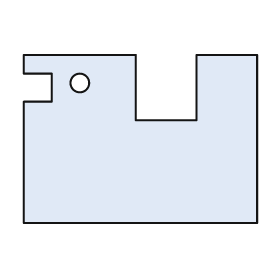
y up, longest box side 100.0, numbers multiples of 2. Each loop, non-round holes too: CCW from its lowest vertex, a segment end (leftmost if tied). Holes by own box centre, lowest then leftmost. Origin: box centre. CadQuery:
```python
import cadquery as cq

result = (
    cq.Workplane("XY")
    .moveTo(-50.0, -36.0)
    .lineTo(50.0, -36.0)
    .lineTo(50.0, 36.0)
    .lineTo(24.0, 36.0)
    .lineTo(24.0, 8.0)
    .lineTo(-2.0, 8.0)
    .lineTo(-2.0, 36.0)
    .lineTo(-50.0, 36.0)
    .lineTo(-50.0, 28.0)
    .lineTo(-38.0, 28.0)
    .lineTo(-38.0, 16.0)
    .lineTo(-50.0, 16.0)
    .close()
    .moveTo(-26.0, 24.0)
    .circle(4.0)
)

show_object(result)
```